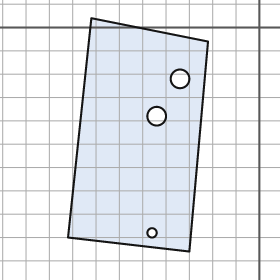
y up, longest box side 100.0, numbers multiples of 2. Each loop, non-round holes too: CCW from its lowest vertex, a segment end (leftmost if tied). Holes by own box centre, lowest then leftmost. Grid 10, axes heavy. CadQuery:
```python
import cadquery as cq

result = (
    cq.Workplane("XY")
    .moveTo(-30.0, -96.0)
    .lineTo(-22.0, -6.0)
    .lineTo(-72.0, 4.0)
    .lineTo(-82.0, -90.0)
    .close()
    .moveTo(-46.0, -88.0)
    .circle(2.0)
    .moveTo(-44.0, -38.0)
    .circle(4.0)
    .moveTo(-34.0, -22.0)
    .circle(4.0)
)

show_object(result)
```